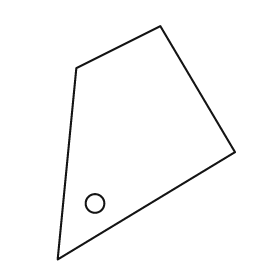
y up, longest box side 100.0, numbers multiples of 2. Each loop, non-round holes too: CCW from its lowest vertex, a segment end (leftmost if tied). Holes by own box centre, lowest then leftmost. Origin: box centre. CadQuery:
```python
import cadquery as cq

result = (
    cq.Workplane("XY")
    .moveTo(-38.0, -50.0)
    .lineTo(38.0, -4.0)
    .lineTo(6.0, 50.0)
    .lineTo(-30.0, 32.0)
    .close()
    .moveTo(-22.0, -26.0)
    .circle(4.0)
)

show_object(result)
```